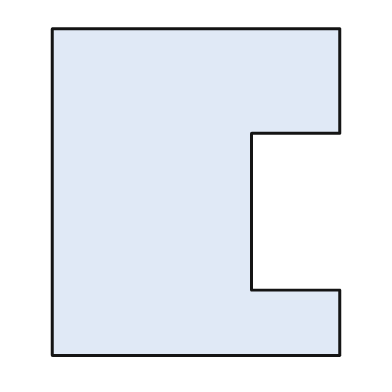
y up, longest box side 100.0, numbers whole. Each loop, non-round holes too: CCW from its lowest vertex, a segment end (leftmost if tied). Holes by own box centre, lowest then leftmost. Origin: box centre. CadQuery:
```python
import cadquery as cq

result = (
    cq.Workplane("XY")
    .moveTo(-44.0, -50.0)
    .lineTo(44.0, -50.0)
    .lineTo(44.0, -30.0)
    .lineTo(17.0, -30.0)
    .lineTo(17.0, 18.0)
    .lineTo(44.0, 18.0)
    .lineTo(44.0, 50.0)
    .lineTo(-44.0, 50.0)
    .close()
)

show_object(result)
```